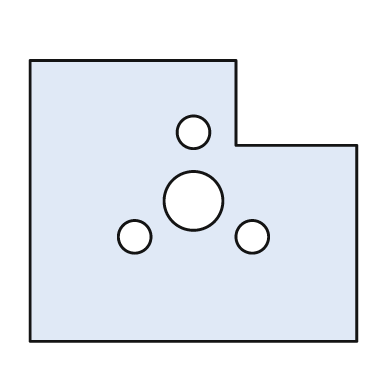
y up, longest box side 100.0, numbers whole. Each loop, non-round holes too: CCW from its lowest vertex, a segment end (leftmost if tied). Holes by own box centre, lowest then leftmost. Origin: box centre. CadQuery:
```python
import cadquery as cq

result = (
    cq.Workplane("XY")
    .moveTo(-50.0, -43.0)
    .lineTo(50.0, -43.0)
    .lineTo(50.0, 17.0)
    .lineTo(13.0, 17.0)
    .lineTo(13.0, 43.0)
    .lineTo(-50.0, 43.0)
    .close()
    .moveTo(-18.0, -11.0)
    .circle(5.0)
    .moveTo(18.0, -11.0)
    .circle(5.0)
    .moveTo(0.0, 0.0)
    .circle(9.0)
    .moveTo(0.0, 21.0)
    .circle(5.0)
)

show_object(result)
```